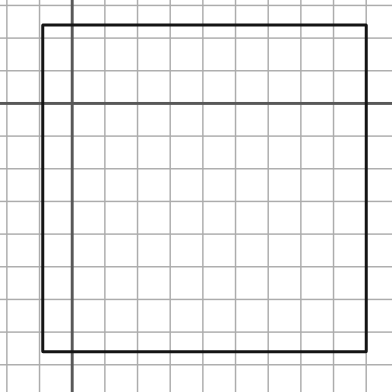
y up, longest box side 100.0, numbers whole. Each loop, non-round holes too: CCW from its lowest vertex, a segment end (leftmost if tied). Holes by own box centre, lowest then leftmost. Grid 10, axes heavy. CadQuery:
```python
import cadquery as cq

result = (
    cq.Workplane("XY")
    .moveTo(-9.0, -76.0)
    .lineTo(90.0, -76.0)
    .lineTo(90.0, 24.0)
    .lineTo(-9.0, 24.0)
    .close()
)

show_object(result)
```